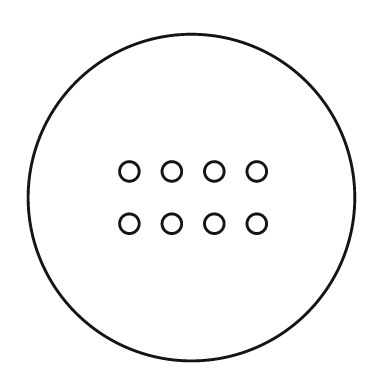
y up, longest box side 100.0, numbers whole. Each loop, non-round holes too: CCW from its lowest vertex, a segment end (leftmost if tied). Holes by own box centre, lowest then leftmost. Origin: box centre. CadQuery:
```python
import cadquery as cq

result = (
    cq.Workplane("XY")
    .moveTo(0.0, 0.0)
    .circle(50.0)
    .moveTo(-19.0, -8.0)
    .circle(3.0)
    .moveTo(-6.0, -8.0)
    .circle(3.0)
    .moveTo(7.0, -8.0)
    .circle(3.0)
    .moveTo(20.0, -8.0)
    .circle(3.0)
    .moveTo(-19.0, 8.0)
    .circle(3.0)
    .moveTo(-6.0, 8.0)
    .circle(3.0)
    .moveTo(7.0, 8.0)
    .circle(3.0)
    .moveTo(20.0, 8.0)
    .circle(3.0)
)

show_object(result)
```